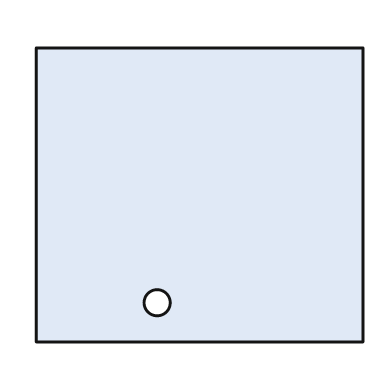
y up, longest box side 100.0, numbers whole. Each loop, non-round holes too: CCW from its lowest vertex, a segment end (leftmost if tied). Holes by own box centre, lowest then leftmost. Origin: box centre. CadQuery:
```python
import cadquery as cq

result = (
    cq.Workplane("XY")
    .moveTo(-50.0, -45.0)
    .lineTo(50.0, -45.0)
    .lineTo(50.0, 45.0)
    .lineTo(-50.0, 45.0)
    .close()
    .moveTo(-13.0, -33.0)
    .circle(4.0)
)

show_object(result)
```